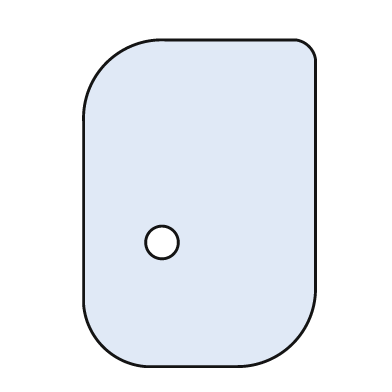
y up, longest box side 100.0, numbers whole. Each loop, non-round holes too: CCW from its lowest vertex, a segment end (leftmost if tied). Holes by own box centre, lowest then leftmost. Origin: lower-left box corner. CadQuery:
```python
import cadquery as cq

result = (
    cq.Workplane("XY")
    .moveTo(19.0, 0.0)
    .lineTo(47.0, 0.0)
    .threePointArc((64.0, 7.0), (71.0, 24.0))
    .lineTo(71.0, 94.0)
    .threePointArc((69.0, 98.0), (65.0, 100.0))
    .lineTo(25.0, 100.0)
    .threePointArc((7.0, 93.0), (0.0, 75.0))
    .lineTo(0.0, 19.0)
    .threePointArc((6.0, 6.0), (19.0, 0.0))
    .close()
    .moveTo(24.0, 38.0)
    .circle(5.0)
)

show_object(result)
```